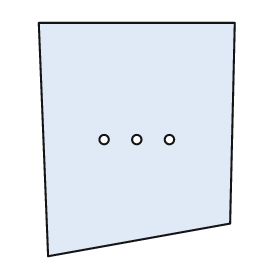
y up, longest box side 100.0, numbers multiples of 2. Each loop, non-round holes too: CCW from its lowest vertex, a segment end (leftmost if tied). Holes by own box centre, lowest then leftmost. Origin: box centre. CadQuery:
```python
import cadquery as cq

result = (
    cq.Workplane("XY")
    .moveTo(-38.0, -50.0)
    .lineTo(40.0, -36.0)
    .lineTo(42.0, 50.0)
    .lineTo(-42.0, 50.0)
    .close()
    .moveTo(-14.0, 0.0)
    .circle(2.0)
    .moveTo(0.0, 0.0)
    .circle(2.0)
    .moveTo(14.0, 0.0)
    .circle(2.0)
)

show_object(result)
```